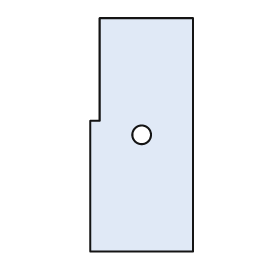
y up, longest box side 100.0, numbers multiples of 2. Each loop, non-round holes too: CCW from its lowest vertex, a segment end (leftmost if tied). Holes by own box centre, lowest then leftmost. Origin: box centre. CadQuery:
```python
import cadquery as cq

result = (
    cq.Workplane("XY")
    .moveTo(-22.0, -50.0)
    .lineTo(22.0, -50.0)
    .lineTo(22.0, 50.0)
    .lineTo(-18.0, 50.0)
    .lineTo(-18.0, 6.0)
    .lineTo(-22.0, 6.0)
    .close()
    .moveTo(0.0, 0.0)
    .circle(4.0)
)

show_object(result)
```